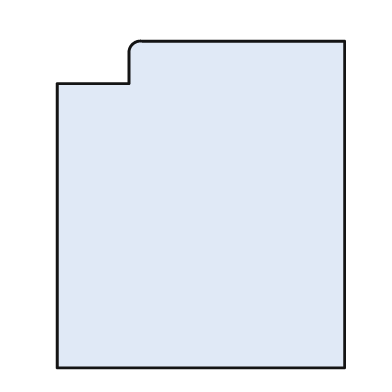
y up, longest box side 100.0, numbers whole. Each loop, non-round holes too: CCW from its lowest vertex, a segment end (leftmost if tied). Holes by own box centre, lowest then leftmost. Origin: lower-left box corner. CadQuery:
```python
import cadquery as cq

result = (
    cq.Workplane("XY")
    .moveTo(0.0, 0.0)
    .lineTo(88.0, 0.0)
    .lineTo(88.0, 100.0)
    .lineTo(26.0, 100.0)
    .threePointArc((23.0, 99.0), (22.0, 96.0))
    .lineTo(22.0, 87.0)
    .lineTo(0.0, 87.0)
    .close()
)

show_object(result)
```